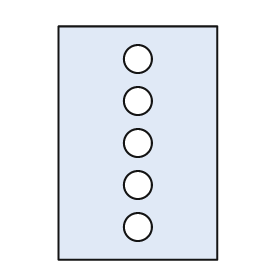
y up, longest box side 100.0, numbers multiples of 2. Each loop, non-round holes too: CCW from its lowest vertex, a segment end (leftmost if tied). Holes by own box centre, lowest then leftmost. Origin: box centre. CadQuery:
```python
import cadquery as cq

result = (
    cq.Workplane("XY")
    .moveTo(-34.0, -50.0)
    .lineTo(34.0, -50.0)
    .lineTo(34.0, 50.0)
    .lineTo(-34.0, 50.0)
    .close()
    .moveTo(0.0, -36.0)
    .circle(6.0)
    .moveTo(0.0, -18.0)
    .circle(6.0)
    .moveTo(0.0, 0.0)
    .circle(6.0)
    .moveTo(0.0, 18.0)
    .circle(6.0)
    .moveTo(0.0, 36.0)
    .circle(6.0)
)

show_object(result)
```